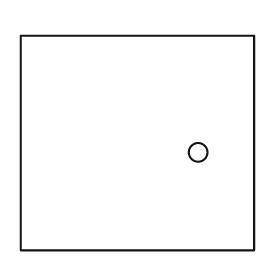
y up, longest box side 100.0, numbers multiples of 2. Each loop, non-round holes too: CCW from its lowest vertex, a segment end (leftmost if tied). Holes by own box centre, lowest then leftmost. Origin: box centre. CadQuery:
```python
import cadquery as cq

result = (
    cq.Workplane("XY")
    .moveTo(-50.0, -46.0)
    .lineTo(50.0, -46.0)
    .lineTo(50.0, 46.0)
    .lineTo(-50.0, 46.0)
    .close()
    .moveTo(26.0, -4.0)
    .circle(4.0)
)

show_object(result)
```